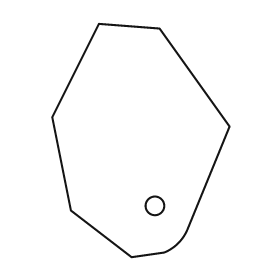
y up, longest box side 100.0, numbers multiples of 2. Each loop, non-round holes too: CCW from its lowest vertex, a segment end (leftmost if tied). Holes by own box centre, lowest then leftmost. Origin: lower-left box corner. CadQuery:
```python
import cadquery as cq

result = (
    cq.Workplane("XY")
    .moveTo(34.0, 0.0)
    .lineTo(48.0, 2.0)
    .threePointArc((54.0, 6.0), (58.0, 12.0))
    .lineTo(76.0, 56.0)
    .lineTo(46.0, 98.0)
    .lineTo(20.0, 100.0)
    .lineTo(0.0, 60.0)
    .lineTo(8.0, 20.0)
    .close()
    .moveTo(44.0, 22.0)
    .circle(4.0)
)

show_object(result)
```